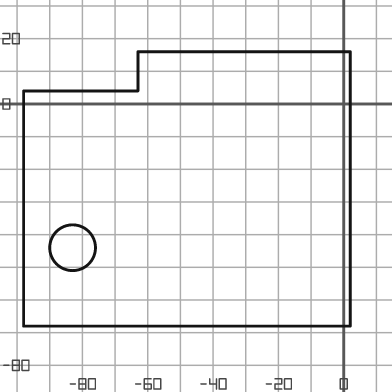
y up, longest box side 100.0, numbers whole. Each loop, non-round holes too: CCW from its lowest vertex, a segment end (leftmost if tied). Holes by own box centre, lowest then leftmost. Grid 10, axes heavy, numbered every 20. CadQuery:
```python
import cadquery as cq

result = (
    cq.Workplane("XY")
    .moveTo(-98.0, -68.0)
    .lineTo(2.0, -68.0)
    .lineTo(2.0, 16.0)
    .lineTo(-63.0, 16.0)
    .lineTo(-63.0, 4.0)
    .lineTo(-98.0, 4.0)
    .close()
    .moveTo(-83.0, -44.0)
    .circle(7.0)
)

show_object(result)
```